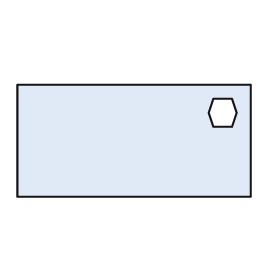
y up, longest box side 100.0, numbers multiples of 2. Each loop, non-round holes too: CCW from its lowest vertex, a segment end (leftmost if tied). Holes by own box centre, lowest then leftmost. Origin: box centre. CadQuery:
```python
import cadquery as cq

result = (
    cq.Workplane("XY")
    .moveTo(-50.0, -24.0)
    .lineTo(50.0, -24.0)
    .lineTo(50.0, 24.0)
    .lineTo(-50.0, 24.0)
    .close()
    .moveTo(34.0, 6.0)
    .lineTo(42.0, 6.0)
    .lineTo(44.0, 12.0)
    .lineTo(42.0, 18.0)
    .lineTo(34.0, 18.0)
    .lineTo(32.0, 12.0)
    .close()
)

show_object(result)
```